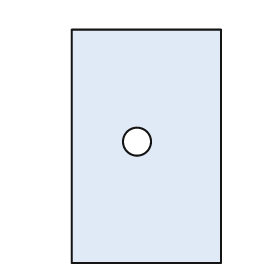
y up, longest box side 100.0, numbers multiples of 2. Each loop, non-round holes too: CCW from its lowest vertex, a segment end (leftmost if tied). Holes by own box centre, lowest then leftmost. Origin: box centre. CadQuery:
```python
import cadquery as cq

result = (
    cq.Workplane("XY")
    .moveTo(-32.0, -50.0)
    .lineTo(32.0, -50.0)
    .lineTo(32.0, 50.0)
    .lineTo(-32.0, 50.0)
    .close()
    .moveTo(-4.0, 2.0)
    .circle(6.0)
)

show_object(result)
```